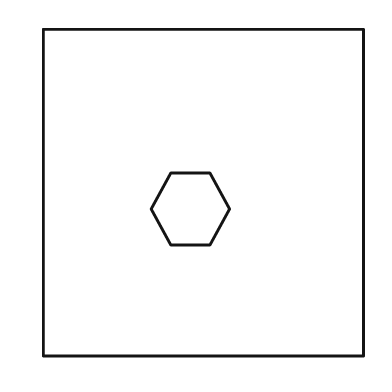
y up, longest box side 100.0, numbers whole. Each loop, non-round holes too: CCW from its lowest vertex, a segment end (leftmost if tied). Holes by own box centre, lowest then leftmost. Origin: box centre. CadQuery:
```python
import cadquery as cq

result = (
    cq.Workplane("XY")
    .moveTo(-49.0, -50.0)
    .lineTo(49.0, -50.0)
    .lineTo(49.0, 50.0)
    .lineTo(-49.0, 50.0)
    .close()
    .moveTo(-10.0, -16.0)
    .lineTo(2.0, -16.0)
    .lineTo(8.0, -5.0)
    .lineTo(2.0, 6.0)
    .lineTo(-10.0, 6.0)
    .lineTo(-16.0, -5.0)
    .close()
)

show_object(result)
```